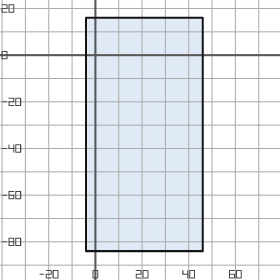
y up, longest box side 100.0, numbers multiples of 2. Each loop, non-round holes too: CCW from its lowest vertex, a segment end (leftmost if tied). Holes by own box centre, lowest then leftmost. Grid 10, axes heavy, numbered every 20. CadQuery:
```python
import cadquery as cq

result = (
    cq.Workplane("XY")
    .moveTo(-4.0, -84.0)
    .lineTo(46.0, -84.0)
    .lineTo(46.0, 16.0)
    .lineTo(-4.0, 16.0)
    .close()
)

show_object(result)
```